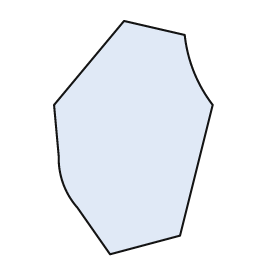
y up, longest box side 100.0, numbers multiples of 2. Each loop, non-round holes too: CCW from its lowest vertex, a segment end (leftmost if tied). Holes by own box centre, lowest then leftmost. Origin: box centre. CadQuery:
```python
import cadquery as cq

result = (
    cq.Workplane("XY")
    .moveTo(-10.0, -50.0)
    .lineTo(20.0, -42.0)
    .lineTo(34.0, 14.0)
    .threePointArc((26.0, 28.0), (22.0, 44.0))
    .lineTo(-4.0, 50.0)
    .lineTo(-34.0, 14.0)
    .lineTo(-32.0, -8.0)
    .threePointArc((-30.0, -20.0), (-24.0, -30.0))
    .close()
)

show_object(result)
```